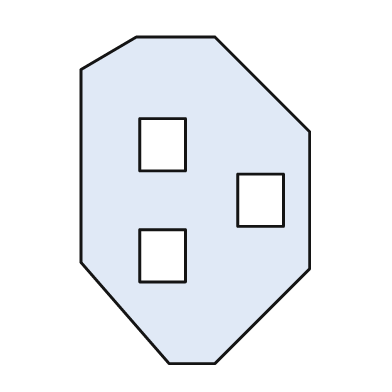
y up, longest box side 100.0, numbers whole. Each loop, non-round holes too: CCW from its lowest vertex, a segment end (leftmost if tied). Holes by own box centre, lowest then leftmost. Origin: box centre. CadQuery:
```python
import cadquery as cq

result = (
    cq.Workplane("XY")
    .moveTo(-8.0, -50.0)
    .lineTo(6.0, -50.0)
    .lineTo(35.0, -21.0)
    .lineTo(35.0, 21.0)
    .lineTo(6.0, 50.0)
    .lineTo(-18.0, 50.0)
    .lineTo(-35.0, 40.0)
    .lineTo(-35.0, -19.0)
    .close()
    .moveTo(-17.0, -25.0)
    .lineTo(-3.0, -25.0)
    .lineTo(-3.0, -9.0)
    .lineTo(-17.0, -9.0)
    .close()
    .moveTo(13.0, -8.0)
    .lineTo(27.0, -8.0)
    .lineTo(27.0, 8.0)
    .lineTo(13.0, 8.0)
    .close()
    .moveTo(-17.0, 9.0)
    .lineTo(-3.0, 9.0)
    .lineTo(-3.0, 25.0)
    .lineTo(-17.0, 25.0)
    .close()
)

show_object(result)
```